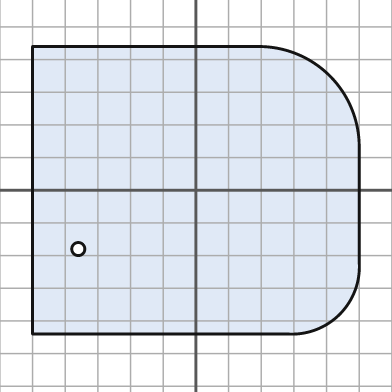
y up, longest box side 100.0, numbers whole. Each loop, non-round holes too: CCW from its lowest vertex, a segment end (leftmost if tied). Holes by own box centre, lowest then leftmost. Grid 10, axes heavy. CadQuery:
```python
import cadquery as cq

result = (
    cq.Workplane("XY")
    .moveTo(-50.0, -44.0)
    .lineTo(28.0, -44.0)
    .threePointArc((44.0, -38.0), (50.0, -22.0))
    .lineTo(50.0, 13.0)
    .threePointArc((41.0, 35.0), (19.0, 44.0))
    .lineTo(-50.0, 44.0)
    .close()
    .moveTo(-36.0, -18.0)
    .circle(2.0)
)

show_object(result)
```